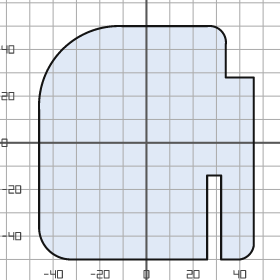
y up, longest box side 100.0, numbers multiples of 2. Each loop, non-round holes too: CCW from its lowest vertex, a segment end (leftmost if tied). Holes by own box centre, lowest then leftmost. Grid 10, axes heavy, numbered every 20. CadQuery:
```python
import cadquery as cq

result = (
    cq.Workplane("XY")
    .moveTo(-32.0, -50.0)
    .lineTo(26.0, -50.0)
    .lineTo(26.0, -14.0)
    .lineTo(32.0, -14.0)
    .lineTo(32.0, -50.0)
    .lineTo(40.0, -50.0)
    .threePointArc((44.0, -48.0), (46.0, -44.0))
    .lineTo(46.0, 28.0)
    .lineTo(34.0, 28.0)
    .lineTo(34.0, 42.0)
    .threePointArc((32.0, 48.0), (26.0, 50.0))
    .lineTo(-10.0, 50.0)
    .threePointArc((-36.0, 40.0), (-46.0, 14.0))
    .lineTo(-46.0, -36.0)
    .threePointArc((-42.0, -46.0), (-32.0, -50.0))
    .close()
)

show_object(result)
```